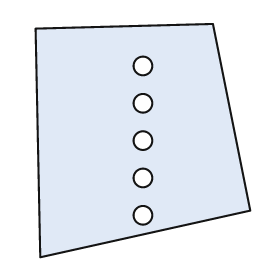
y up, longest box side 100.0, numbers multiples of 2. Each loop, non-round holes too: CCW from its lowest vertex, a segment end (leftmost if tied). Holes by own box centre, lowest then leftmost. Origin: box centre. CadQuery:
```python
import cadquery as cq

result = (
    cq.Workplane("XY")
    .moveTo(-44.0, -50.0)
    .lineTo(46.0, -30.0)
    .lineTo(30.0, 50.0)
    .lineTo(-46.0, 48.0)
    .close()
    .moveTo(0.0, -32.0)
    .circle(4.0)
    .moveTo(0.0, -16.0)
    .circle(4.0)
    .moveTo(0.0, 0.0)
    .circle(4.0)
    .moveTo(0.0, 16.0)
    .circle(4.0)
    .moveTo(0.0, 32.0)
    .circle(4.0)
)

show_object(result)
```